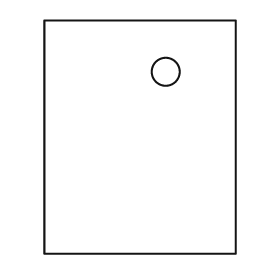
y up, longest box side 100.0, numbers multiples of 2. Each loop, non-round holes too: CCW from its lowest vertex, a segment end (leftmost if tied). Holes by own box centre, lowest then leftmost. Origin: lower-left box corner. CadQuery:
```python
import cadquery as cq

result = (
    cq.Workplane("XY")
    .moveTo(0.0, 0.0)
    .lineTo(82.0, 0.0)
    .lineTo(82.0, 100.0)
    .lineTo(0.0, 100.0)
    .close()
    .moveTo(52.0, 78.0)
    .circle(6.0)
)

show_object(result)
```